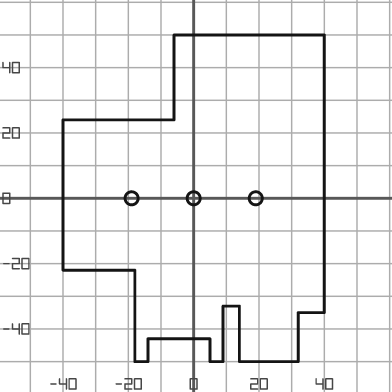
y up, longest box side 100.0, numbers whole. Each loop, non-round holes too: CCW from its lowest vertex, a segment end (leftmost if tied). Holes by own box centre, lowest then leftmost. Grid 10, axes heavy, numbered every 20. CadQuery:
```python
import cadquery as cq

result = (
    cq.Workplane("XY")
    .moveTo(-18.0, -50.0)
    .lineTo(-14.0, -50.0)
    .lineTo(-14.0, -43.0)
    .lineTo(5.0, -43.0)
    .lineTo(5.0, -50.0)
    .lineTo(9.0, -50.0)
    .lineTo(9.0, -33.0)
    .lineTo(14.0, -33.0)
    .lineTo(14.0, -50.0)
    .lineTo(32.0, -50.0)
    .lineTo(32.0, -35.0)
    .lineTo(40.0, -35.0)
    .lineTo(40.0, 50.0)
    .lineTo(-6.0, 50.0)
    .lineTo(-6.0, 24.0)
    .lineTo(-40.0, 24.0)
    .lineTo(-40.0, -22.0)
    .lineTo(-18.0, -22.0)
    .close()
    .moveTo(-19.0, 0.0)
    .circle(2.0)
    .moveTo(0.0, 0.0)
    .circle(2.0)
    .moveTo(19.0, 0.0)
    .circle(2.0)
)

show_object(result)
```